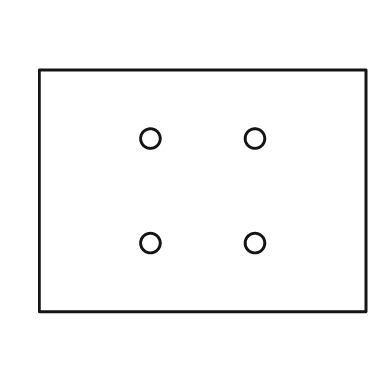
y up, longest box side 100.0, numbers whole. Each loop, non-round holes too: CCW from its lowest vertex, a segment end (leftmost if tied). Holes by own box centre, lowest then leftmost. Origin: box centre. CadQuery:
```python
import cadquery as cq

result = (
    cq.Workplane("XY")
    .moveTo(-50.0, -37.0)
    .lineTo(50.0, -37.0)
    .lineTo(50.0, 37.0)
    .lineTo(-50.0, 37.0)
    .close()
    .moveTo(-16.0, -16.0)
    .circle(3.0)
    .moveTo(16.0, -16.0)
    .circle(3.0)
    .moveTo(-16.0, 16.0)
    .circle(3.0)
    .moveTo(16.0, 16.0)
    .circle(3.0)
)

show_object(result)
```